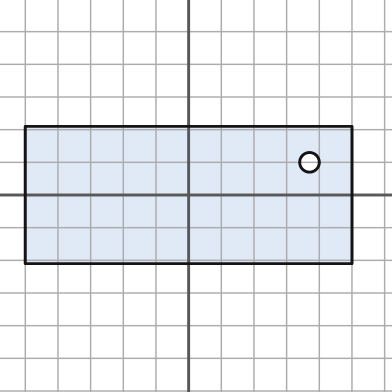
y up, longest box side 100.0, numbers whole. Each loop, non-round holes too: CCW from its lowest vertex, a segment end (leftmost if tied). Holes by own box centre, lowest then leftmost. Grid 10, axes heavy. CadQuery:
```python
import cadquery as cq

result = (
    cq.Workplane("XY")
    .moveTo(-50.0, -21.0)
    .lineTo(50.0, -21.0)
    .lineTo(50.0, 21.0)
    .lineTo(-50.0, 21.0)
    .close()
    .moveTo(37.0, 10.0)
    .circle(3.0)
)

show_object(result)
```